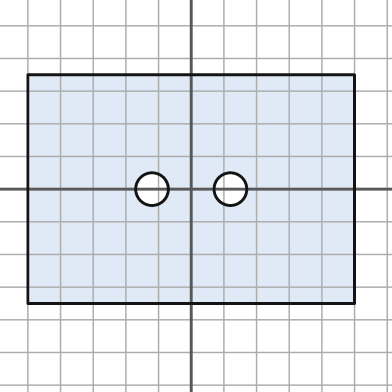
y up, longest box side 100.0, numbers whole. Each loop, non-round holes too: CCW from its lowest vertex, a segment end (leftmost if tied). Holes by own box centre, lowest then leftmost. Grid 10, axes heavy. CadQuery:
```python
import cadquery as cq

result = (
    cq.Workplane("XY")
    .moveTo(-50.0, -35.0)
    .lineTo(50.0, -35.0)
    .lineTo(50.0, 35.0)
    .lineTo(-50.0, 35.0)
    .close()
    .moveTo(-12.0, 0.0)
    .circle(5.0)
    .moveTo(12.0, 0.0)
    .circle(5.0)
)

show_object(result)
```